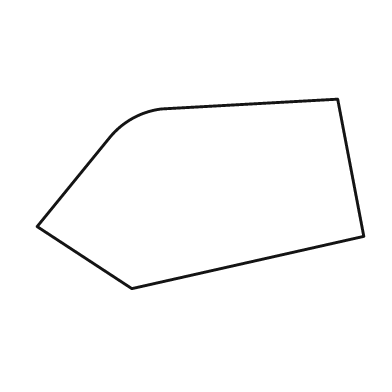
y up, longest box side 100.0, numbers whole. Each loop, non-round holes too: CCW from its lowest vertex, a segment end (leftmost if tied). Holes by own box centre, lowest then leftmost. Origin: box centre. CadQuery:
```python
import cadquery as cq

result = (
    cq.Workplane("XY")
    .moveTo(-21.0, -29.0)
    .lineTo(50.0, -13.0)
    .lineTo(42.0, 29.0)
    .lineTo(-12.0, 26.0)
    .threePointArc((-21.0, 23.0), (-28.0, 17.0))
    .lineTo(-50.0, -10.0)
    .close()
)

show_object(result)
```